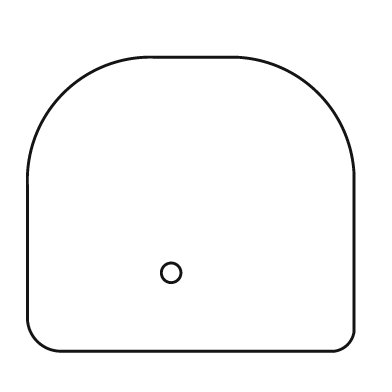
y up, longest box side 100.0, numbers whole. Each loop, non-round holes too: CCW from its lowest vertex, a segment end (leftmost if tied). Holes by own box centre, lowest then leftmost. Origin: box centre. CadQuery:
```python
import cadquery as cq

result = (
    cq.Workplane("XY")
    .moveTo(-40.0, -45.0)
    .lineTo(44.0, -45.0)
    .threePointArc((48.0, -43.0), (50.0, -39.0))
    .lineTo(50.0, 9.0)
    .threePointArc((39.0, 34.0), (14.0, 45.0))
    .lineTo(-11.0, 45.0)
    .threePointArc((-39.0, 34.0), (-50.0, 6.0))
    .lineTo(-50.0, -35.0)
    .threePointArc((-47.0, -42.0), (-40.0, -45.0))
    .close()
    .moveTo(-6.0, -21.0)
    .circle(3.0)
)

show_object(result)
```